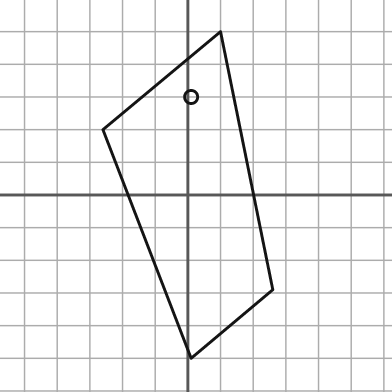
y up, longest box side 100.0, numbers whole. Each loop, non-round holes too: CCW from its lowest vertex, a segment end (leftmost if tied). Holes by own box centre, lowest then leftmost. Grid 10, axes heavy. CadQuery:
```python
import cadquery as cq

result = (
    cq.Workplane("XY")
    .moveTo(1.0, -50.0)
    .lineTo(26.0, -29.0)
    .lineTo(10.0, 50.0)
    .lineTo(-26.0, 20.0)
    .close()
    .moveTo(1.0, 30.0)
    .circle(2.0)
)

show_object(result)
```